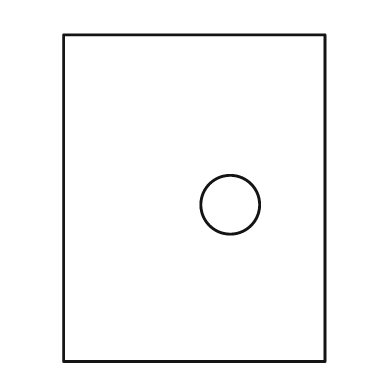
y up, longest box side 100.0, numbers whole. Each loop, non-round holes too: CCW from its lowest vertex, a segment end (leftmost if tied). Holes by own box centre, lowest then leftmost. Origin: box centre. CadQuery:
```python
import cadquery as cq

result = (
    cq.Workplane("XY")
    .moveTo(-40.0, -50.0)
    .lineTo(40.0, -50.0)
    .lineTo(40.0, 50.0)
    .lineTo(-40.0, 50.0)
    .close()
    .moveTo(11.0, -2.0)
    .circle(9.0)
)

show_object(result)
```